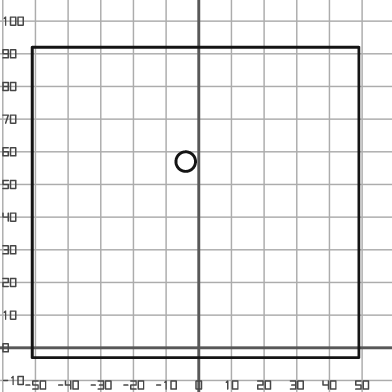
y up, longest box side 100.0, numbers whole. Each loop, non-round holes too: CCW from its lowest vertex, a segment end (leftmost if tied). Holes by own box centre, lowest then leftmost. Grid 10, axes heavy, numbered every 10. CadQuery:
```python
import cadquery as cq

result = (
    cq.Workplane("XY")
    .moveTo(-51.0, -3.0)
    .lineTo(49.0, -3.0)
    .lineTo(49.0, 92.0)
    .lineTo(-51.0, 92.0)
    .close()
    .moveTo(-4.0, 57.0)
    .circle(3.0)
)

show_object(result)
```